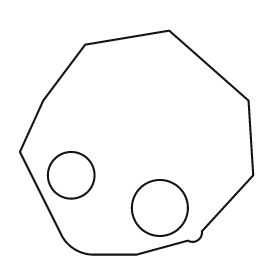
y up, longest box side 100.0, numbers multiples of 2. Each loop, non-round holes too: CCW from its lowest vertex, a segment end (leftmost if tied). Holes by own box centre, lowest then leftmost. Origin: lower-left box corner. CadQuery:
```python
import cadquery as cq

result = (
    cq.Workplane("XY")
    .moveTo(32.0, 0.0)
    .lineTo(50.0, 0.0)
    .lineTo(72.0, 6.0)
    .threePointArc((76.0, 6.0), (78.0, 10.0))
    .lineTo(100.0, 34.0)
    .lineTo(98.0, 66.0)
    .lineTo(64.0, 96.0)
    .lineTo(28.0, 90.0)
    .lineTo(10.0, 66.0)
    .lineTo(0.0, 44.0)
    .lineTo(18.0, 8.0)
    .threePointArc((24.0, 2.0), (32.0, 0.0))
    .close()
    .moveTo(60.0, 20.0)
    .circle(12.0)
    .moveTo(22.0, 34.0)
    .circle(10.0)
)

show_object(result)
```